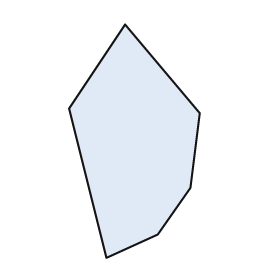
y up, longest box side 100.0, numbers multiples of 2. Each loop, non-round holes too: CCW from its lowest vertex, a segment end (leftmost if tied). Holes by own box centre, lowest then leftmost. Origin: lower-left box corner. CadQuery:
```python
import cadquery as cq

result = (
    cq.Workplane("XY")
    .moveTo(16.0, 0.0)
    .lineTo(38.0, 10.0)
    .lineTo(52.0, 30.0)
    .lineTo(56.0, 62.0)
    .lineTo(24.0, 100.0)
    .lineTo(0.0, 64.0)
    .close()
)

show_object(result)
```